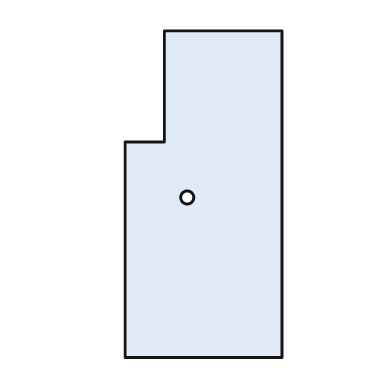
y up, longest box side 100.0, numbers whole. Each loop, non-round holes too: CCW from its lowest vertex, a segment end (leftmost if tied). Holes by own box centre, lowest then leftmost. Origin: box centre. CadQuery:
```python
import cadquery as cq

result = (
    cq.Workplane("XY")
    .moveTo(-24.0, -50.0)
    .lineTo(24.0, -50.0)
    .lineTo(24.0, 50.0)
    .lineTo(-12.0, 50.0)
    .lineTo(-12.0, 16.0)
    .lineTo(-24.0, 16.0)
    .close()
    .moveTo(-5.0, -1.0)
    .circle(2.0)
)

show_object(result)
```